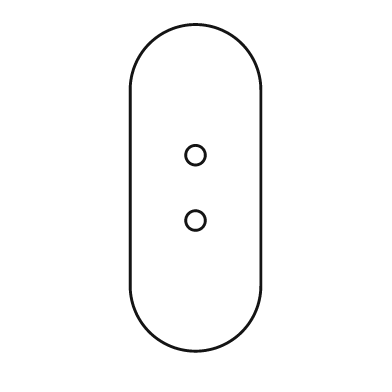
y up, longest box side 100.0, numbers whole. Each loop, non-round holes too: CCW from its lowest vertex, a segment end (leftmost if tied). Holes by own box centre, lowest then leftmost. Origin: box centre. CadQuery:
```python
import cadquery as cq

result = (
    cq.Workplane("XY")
    .moveTo(-20.0, -30.0)
    .threePointArc((0.0, -50.0), (20.0, -30.0))
    .lineTo(20.0, 30.0)
    .threePointArc((0.0, 50.0), (-20.0, 30.0))
    .close()
    .moveTo(0.0, -10.0)
    .circle(3.0)
    .moveTo(0.0, 10.0)
    .circle(3.0)
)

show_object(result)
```